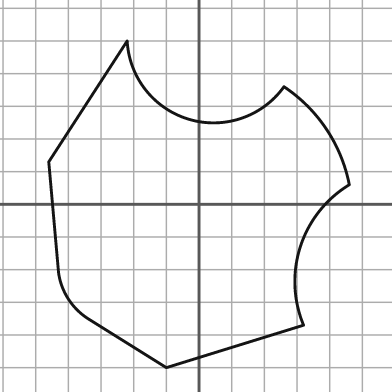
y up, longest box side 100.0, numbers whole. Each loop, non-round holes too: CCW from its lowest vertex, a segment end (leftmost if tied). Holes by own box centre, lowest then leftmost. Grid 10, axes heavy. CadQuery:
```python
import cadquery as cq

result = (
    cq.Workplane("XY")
    .moveTo(-10.0, -50.0)
    .lineTo(32.0, -37.0)
    .threePointArc((31.0, -13.0), (46.0, 6.0))
    .threePointArc((39.0, 23.0), (26.0, 36.0))
    .threePointArc((-3.0, 26.0), (-22.0, 50.0))
    .lineTo(-46.0, 13.0)
    .lineTo(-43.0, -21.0)
    .threePointArc((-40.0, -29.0), (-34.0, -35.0))
    .close()
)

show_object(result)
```